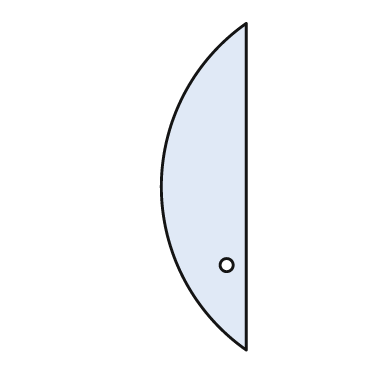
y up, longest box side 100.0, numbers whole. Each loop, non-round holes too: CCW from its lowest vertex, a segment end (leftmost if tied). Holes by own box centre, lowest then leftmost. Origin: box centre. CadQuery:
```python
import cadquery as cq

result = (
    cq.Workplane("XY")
    .moveTo(13.0, -50.0)
    .lineTo(13.0, 50.0)
    .threePointArc((-13.0, 0.0), (13.0, -50.0))
    .close()
    .moveTo(7.0, -24.0)
    .circle(2.0)
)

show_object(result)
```